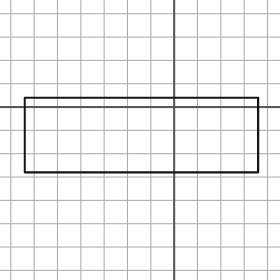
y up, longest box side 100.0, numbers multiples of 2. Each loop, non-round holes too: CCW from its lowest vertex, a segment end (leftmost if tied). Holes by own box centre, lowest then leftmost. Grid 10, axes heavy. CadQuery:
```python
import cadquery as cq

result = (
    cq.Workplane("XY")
    .moveTo(-64.0, -28.0)
    .lineTo(36.0, -28.0)
    .lineTo(36.0, 4.0)
    .lineTo(-64.0, 4.0)
    .close()
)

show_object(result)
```